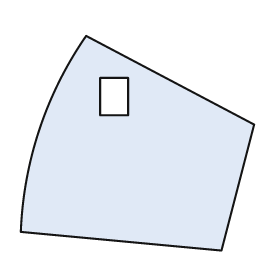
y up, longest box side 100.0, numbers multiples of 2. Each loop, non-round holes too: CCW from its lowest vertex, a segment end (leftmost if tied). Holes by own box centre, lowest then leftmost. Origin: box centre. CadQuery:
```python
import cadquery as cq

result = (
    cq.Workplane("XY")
    .moveTo(36.0, -46.0)
    .lineTo(50.0, 8.0)
    .lineTo(-22.0, 46.0)
    .threePointArc((-42.0, 6.0), (-50.0, -38.0))
    .close()
    .moveTo(-16.0, 12.0)
    .lineTo(-4.0, 12.0)
    .lineTo(-4.0, 28.0)
    .lineTo(-16.0, 28.0)
    .close()
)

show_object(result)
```